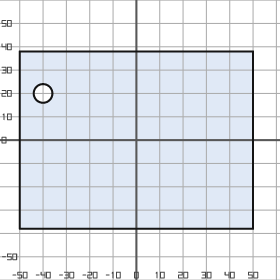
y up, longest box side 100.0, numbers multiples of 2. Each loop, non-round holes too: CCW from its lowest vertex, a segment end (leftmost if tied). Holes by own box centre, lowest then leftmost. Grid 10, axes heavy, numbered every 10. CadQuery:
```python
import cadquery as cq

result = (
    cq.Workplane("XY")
    .moveTo(-50.0, -38.0)
    .lineTo(50.0, -38.0)
    .lineTo(50.0, 38.0)
    .lineTo(-50.0, 38.0)
    .close()
    .moveTo(-40.0, 20.0)
    .circle(4.0)
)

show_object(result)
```